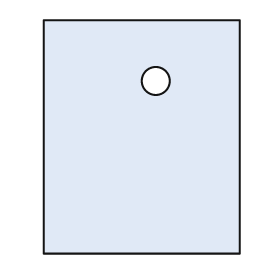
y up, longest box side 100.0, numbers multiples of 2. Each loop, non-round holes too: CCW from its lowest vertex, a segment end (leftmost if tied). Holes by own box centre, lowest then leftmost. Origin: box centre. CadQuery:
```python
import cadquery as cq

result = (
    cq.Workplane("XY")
    .moveTo(-42.0, -50.0)
    .lineTo(42.0, -50.0)
    .lineTo(42.0, 50.0)
    .lineTo(-42.0, 50.0)
    .close()
    .moveTo(6.0, 24.0)
    .circle(6.0)
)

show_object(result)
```